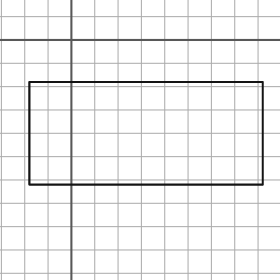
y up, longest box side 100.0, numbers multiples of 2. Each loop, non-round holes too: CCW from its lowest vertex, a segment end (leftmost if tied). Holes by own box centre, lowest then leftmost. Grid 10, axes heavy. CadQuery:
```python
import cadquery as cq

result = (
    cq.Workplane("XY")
    .moveTo(-18.0, -62.0)
    .lineTo(82.0, -62.0)
    .lineTo(82.0, -18.0)
    .lineTo(-18.0, -18.0)
    .close()
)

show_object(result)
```